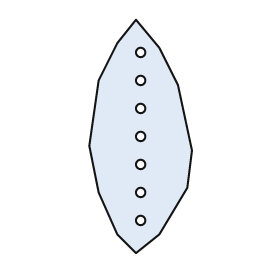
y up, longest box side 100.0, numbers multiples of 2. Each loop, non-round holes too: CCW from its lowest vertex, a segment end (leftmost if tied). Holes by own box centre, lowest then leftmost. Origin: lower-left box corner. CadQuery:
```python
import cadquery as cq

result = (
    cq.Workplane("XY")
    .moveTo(20.0, 0.0)
    .lineTo(30.0, 8.0)
    .lineTo(42.0, 28.0)
    .lineTo(44.0, 44.0)
    .lineTo(38.0, 72.0)
    .lineTo(30.0, 88.0)
    .lineTo(20.0, 100.0)
    .lineTo(12.0, 90.0)
    .lineTo(4.0, 74.0)
    .lineTo(0.0, 46.0)
    .lineTo(4.0, 26.0)
    .lineTo(12.0, 8.0)
    .close()
    .moveTo(22.0, 14.0)
    .circle(2.0)
    .moveTo(22.0, 26.0)
    .circle(2.0)
    .moveTo(22.0, 38.0)
    .circle(2.0)
    .moveTo(22.0, 50.0)
    .circle(2.0)
    .moveTo(22.0, 62.0)
    .circle(2.0)
    .moveTo(22.0, 74.0)
    .circle(2.0)
    .moveTo(22.0, 86.0)
    .circle(2.0)
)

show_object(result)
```